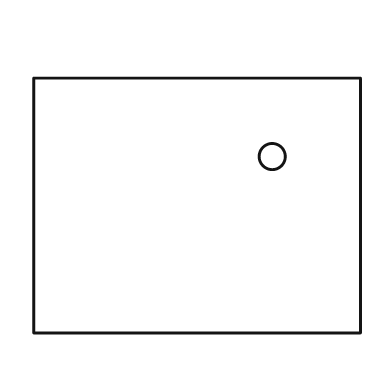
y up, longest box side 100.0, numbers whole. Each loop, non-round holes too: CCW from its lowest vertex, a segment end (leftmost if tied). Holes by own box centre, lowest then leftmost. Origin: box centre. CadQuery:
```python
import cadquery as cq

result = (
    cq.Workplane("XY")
    .moveTo(-50.0, -39.0)
    .lineTo(50.0, -39.0)
    .lineTo(50.0, 39.0)
    .lineTo(-50.0, 39.0)
    .close()
    .moveTo(23.0, 15.0)
    .circle(4.0)
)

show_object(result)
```